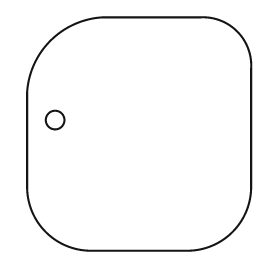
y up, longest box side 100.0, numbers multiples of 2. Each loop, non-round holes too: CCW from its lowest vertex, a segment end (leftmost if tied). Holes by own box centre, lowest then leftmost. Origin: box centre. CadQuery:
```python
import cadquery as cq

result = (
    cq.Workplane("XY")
    .moveTo(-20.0, -50.0)
    .lineTo(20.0, -50.0)
    .threePointArc((40.0, -42.0), (48.0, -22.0))
    .lineTo(48.0, 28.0)
    .threePointArc((42.0, 44.0), (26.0, 50.0))
    .lineTo(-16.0, 50.0)
    .threePointArc((-38.0, 40.0), (-48.0, 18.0))
    .lineTo(-48.0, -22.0)
    .threePointArc((-40.0, -42.0), (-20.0, -50.0))
    .close()
    .moveTo(-36.0, 6.0)
    .circle(4.0)
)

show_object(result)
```